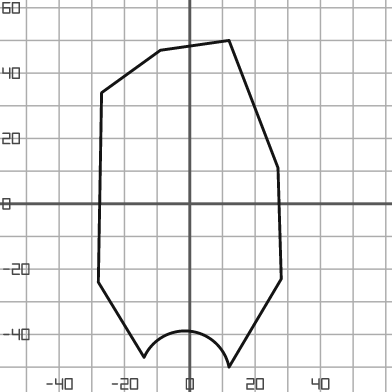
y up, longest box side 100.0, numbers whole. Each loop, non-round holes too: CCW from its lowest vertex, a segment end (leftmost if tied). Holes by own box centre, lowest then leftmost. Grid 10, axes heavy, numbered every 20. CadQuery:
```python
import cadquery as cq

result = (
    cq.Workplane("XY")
    .moveTo(12.0, -50.0)
    .lineTo(28.0, -23.0)
    .lineTo(27.0, 11.0)
    .lineTo(12.0, 50.0)
    .lineTo(-9.0, 47.0)
    .lineTo(-27.0, 34.0)
    .lineTo(-28.0, -24.0)
    .lineTo(-14.0, -47.0)
    .threePointArc((0.0, -39.0), (12.0, -50.0))
    .close()
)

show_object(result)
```